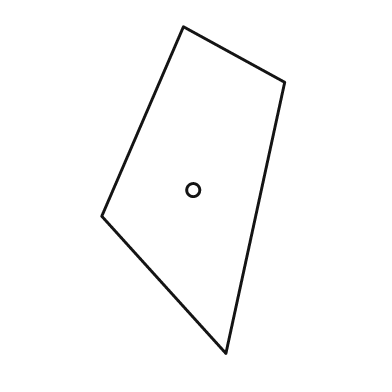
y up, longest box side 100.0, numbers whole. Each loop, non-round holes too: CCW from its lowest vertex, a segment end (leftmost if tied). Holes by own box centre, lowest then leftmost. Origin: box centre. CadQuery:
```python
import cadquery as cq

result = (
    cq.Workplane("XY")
    .moveTo(10.0, -50.0)
    .lineTo(28.0, 33.0)
    .lineTo(-3.0, 50.0)
    .lineTo(-28.0, -8.0)
    .close()
    .moveTo(0.0, 0.0)
    .circle(2.0)
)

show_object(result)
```